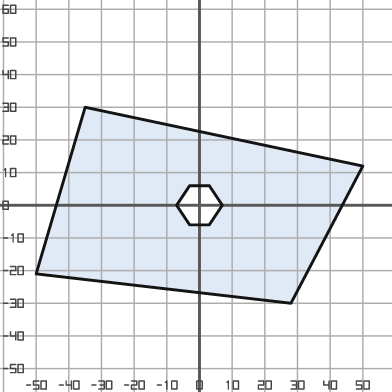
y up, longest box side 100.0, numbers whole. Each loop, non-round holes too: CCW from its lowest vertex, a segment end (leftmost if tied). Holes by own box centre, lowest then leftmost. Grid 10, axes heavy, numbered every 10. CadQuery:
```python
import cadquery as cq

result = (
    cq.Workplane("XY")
    .moveTo(28.0, -30.0)
    .lineTo(50.0, 12.0)
    .lineTo(-35.0, 30.0)
    .lineTo(-50.0, -21.0)
    .close()
    .moveTo(-3.0, -6.0)
    .lineTo(3.0, -6.0)
    .lineTo(7.0, 0.0)
    .lineTo(3.0, 6.0)
    .lineTo(-3.0, 6.0)
    .lineTo(-7.0, 0.0)
    .close()
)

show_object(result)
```